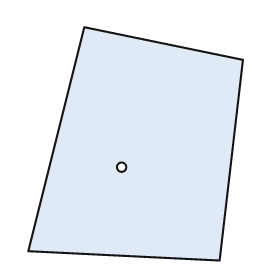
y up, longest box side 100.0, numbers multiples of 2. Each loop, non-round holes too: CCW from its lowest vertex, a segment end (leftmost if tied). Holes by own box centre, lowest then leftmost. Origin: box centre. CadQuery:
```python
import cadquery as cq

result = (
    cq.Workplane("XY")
    .moveTo(36.0, -50.0)
    .lineTo(46.0, 36.0)
    .lineTo(-22.0, 50.0)
    .lineTo(-46.0, -46.0)
    .close()
    .moveTo(-6.0, -10.0)
    .circle(2.0)
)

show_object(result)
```